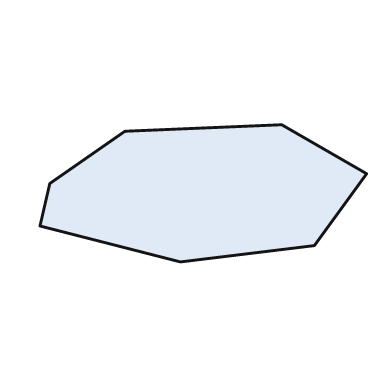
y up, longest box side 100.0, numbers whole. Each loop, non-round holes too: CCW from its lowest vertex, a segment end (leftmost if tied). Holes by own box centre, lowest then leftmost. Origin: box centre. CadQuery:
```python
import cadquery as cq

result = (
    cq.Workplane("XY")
    .moveTo(-7.0, -21.0)
    .lineTo(34.0, -16.0)
    .lineTo(50.0, 6.0)
    .lineTo(24.0, 21.0)
    .lineTo(-24.0, 19.0)
    .lineTo(-47.0, 3.0)
    .lineTo(-50.0, -10.0)
    .close()
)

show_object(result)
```